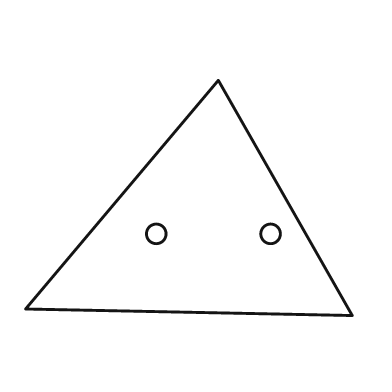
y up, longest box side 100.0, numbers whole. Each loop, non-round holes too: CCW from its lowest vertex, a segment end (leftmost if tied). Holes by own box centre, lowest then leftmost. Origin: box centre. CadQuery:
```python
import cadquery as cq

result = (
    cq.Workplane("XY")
    .moveTo(50.0, -36.0)
    .lineTo(9.0, 36.0)
    .lineTo(-50.0, -34.0)
    .close()
    .moveTo(-10.0, -11.0)
    .circle(3.0)
    .moveTo(25.0, -11.0)
    .circle(3.0)
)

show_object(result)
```